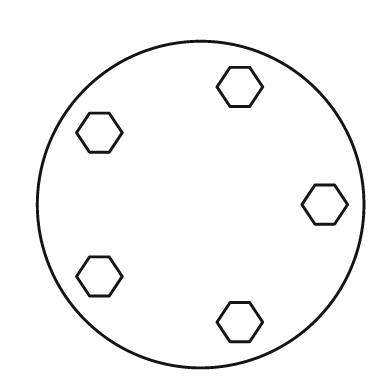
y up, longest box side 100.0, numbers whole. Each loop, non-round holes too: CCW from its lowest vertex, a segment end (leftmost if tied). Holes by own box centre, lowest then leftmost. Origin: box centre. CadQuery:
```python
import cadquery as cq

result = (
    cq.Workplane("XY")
    .moveTo(0.0, 0.0)
    .circle(50.0)
    .moveTo(9.0, -42.0)
    .lineTo(15.0, -42.0)
    .lineTo(19.0, -36.0)
    .lineTo(15.0, -30.0)
    .lineTo(9.0, -30.0)
    .lineTo(5.0, -36.0)
    .close()
    .moveTo(-34.0, -28.0)
    .lineTo(-28.0, -28.0)
    .lineTo(-24.0, -22.0)
    .lineTo(-28.0, -16.0)
    .lineTo(-34.0, -16.0)
    .lineTo(-38.0, -22.0)
    .close()
    .moveTo(35.0, -6.0)
    .lineTo(41.0, -6.0)
    .lineTo(45.0, 0.0)
    .lineTo(41.0, 6.0)
    .lineTo(35.0, 6.0)
    .lineTo(31.0, 0.0)
    .close()
    .moveTo(-34.0, 16.0)
    .lineTo(-28.0, 16.0)
    .lineTo(-24.0, 22.0)
    .lineTo(-28.0, 28.0)
    .lineTo(-34.0, 28.0)
    .lineTo(-38.0, 22.0)
    .close()
    .moveTo(9.0, 30.0)
    .lineTo(15.0, 30.0)
    .lineTo(19.0, 36.0)
    .lineTo(15.0, 42.0)
    .lineTo(9.0, 42.0)
    .lineTo(5.0, 36.0)
    .close()
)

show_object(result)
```